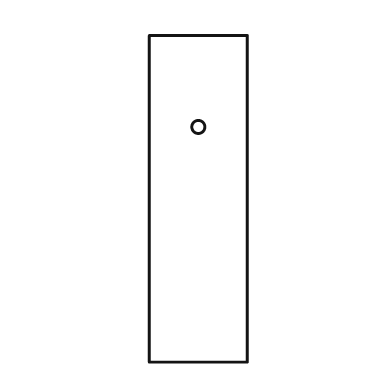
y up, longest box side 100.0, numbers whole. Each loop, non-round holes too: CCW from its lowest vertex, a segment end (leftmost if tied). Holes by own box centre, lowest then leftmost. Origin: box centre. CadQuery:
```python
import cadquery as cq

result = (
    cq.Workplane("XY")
    .moveTo(-15.0, -50.0)
    .lineTo(15.0, -50.0)
    .lineTo(15.0, 50.0)
    .lineTo(-15.0, 50.0)
    .close()
    .moveTo(0.0, 22.0)
    .circle(2.0)
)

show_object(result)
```